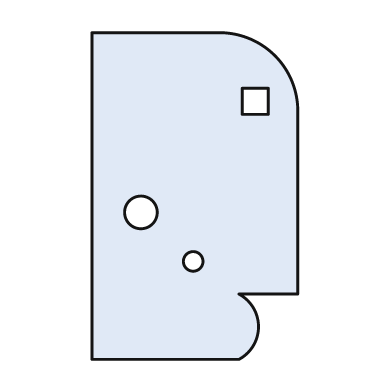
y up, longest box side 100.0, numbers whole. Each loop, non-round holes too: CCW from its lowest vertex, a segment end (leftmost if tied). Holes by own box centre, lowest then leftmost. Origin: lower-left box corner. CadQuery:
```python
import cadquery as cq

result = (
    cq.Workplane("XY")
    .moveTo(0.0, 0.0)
    .lineTo(45.0, 0.0)
    .threePointArc((51.0, 10.0), (45.0, 20.0))
    .lineTo(63.0, 20.0)
    .lineTo(63.0, 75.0)
    .threePointArc((56.0, 93.0), (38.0, 100.0))
    .lineTo(0.0, 100.0)
    .close()
    .moveTo(31.0, 30.0)
    .circle(3.0)
    .moveTo(15.0, 45.0)
    .circle(5.0)
    .moveTo(46.0, 75.0)
    .lineTo(54.0, 75.0)
    .lineTo(54.0, 83.0)
    .lineTo(46.0, 83.0)
    .close()
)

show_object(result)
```